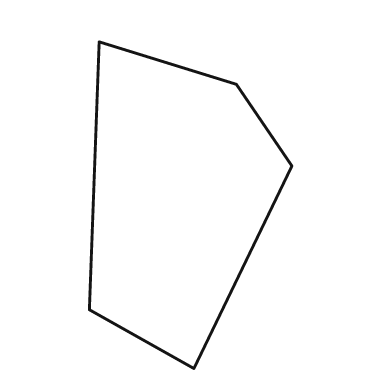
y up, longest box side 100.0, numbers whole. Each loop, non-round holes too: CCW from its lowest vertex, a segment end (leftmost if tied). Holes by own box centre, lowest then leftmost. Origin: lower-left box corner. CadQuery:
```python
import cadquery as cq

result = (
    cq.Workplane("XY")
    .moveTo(32.0, 0.0)
    .lineTo(62.0, 62.0)
    .lineTo(45.0, 87.0)
    .lineTo(3.0, 100.0)
    .lineTo(0.0, 18.0)
    .close()
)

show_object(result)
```